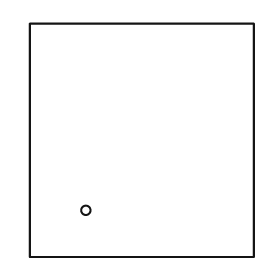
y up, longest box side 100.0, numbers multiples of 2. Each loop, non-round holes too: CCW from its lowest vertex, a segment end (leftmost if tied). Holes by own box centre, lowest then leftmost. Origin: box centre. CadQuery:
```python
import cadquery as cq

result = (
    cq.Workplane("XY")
    .moveTo(-48.0, -50.0)
    .lineTo(48.0, -50.0)
    .lineTo(48.0, 50.0)
    .lineTo(-48.0, 50.0)
    .close()
    .moveTo(-24.0, -30.0)
    .circle(2.0)
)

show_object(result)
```